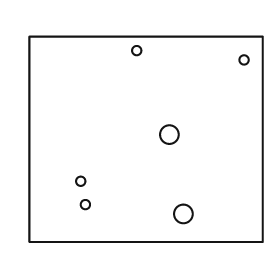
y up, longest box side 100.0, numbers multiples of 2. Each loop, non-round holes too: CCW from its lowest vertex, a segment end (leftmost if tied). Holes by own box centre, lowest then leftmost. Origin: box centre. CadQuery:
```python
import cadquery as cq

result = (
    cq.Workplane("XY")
    .moveTo(-50.0, -44.0)
    .lineTo(50.0, -44.0)
    .lineTo(50.0, 44.0)
    .lineTo(-50.0, 44.0)
    .close()
    .moveTo(16.0, -32.0)
    .circle(4.0)
    .moveTo(-26.0, -28.0)
    .circle(2.0)
    .moveTo(-28.0, -18.0)
    .circle(2.0)
    .moveTo(10.0, 2.0)
    .circle(4.0)
    .moveTo(42.0, 34.0)
    .circle(2.0)
    .moveTo(-4.0, 38.0)
    .circle(2.0)
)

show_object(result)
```